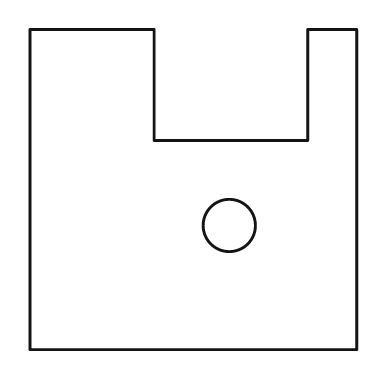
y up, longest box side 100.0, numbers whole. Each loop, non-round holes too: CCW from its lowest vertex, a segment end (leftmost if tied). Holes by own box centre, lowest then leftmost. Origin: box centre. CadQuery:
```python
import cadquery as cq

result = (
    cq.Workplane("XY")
    .moveTo(-50.0, -49.0)
    .lineTo(50.0, -49.0)
    .lineTo(50.0, 49.0)
    .lineTo(35.0, 49.0)
    .lineTo(35.0, 15.0)
    .lineTo(-12.0, 15.0)
    .lineTo(-12.0, 49.0)
    .lineTo(-50.0, 49.0)
    .close()
    .moveTo(11.0, -11.0)
    .circle(8.0)
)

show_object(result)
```